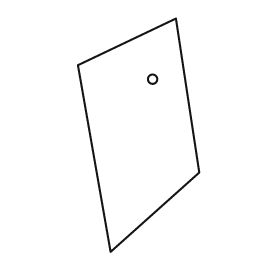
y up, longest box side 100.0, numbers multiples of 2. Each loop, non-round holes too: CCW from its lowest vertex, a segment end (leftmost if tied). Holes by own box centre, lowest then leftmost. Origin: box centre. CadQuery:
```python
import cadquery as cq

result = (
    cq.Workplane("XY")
    .moveTo(-12.0, -50.0)
    .lineTo(26.0, -16.0)
    .lineTo(16.0, 50.0)
    .lineTo(-26.0, 30.0)
    .close()
    .moveTo(6.0, 24.0)
    .circle(2.0)
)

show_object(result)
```